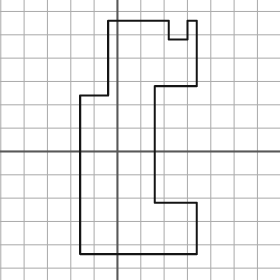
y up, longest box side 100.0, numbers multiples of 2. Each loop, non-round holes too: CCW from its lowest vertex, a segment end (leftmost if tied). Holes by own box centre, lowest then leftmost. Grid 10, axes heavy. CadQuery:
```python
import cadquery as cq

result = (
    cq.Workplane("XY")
    .moveTo(-16.0, -44.0)
    .lineTo(34.0, -44.0)
    .lineTo(34.0, -22.0)
    .lineTo(16.0, -22.0)
    .lineTo(16.0, 28.0)
    .lineTo(34.0, 28.0)
    .lineTo(34.0, 56.0)
    .lineTo(30.0, 56.0)
    .lineTo(30.0, 48.0)
    .lineTo(22.0, 48.0)
    .lineTo(22.0, 56.0)
    .lineTo(-4.0, 56.0)
    .lineTo(-4.0, 24.0)
    .lineTo(-16.0, 24.0)
    .close()
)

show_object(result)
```